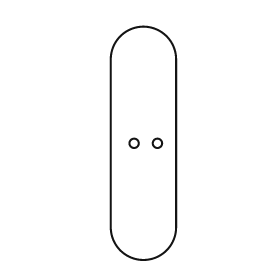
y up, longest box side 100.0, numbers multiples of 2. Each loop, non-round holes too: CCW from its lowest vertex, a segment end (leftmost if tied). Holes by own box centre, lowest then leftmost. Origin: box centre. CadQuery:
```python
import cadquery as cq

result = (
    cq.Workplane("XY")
    .moveTo(-14.0, -36.0)
    .threePointArc((0.0, -50.0), (14.0, -36.0))
    .lineTo(14.0, 36.0)
    .threePointArc((0.0, 50.0), (-14.0, 36.0))
    .close()
    .moveTo(-4.0, 0.0)
    .circle(2.0)
    .moveTo(6.0, 0.0)
    .circle(2.0)
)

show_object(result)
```